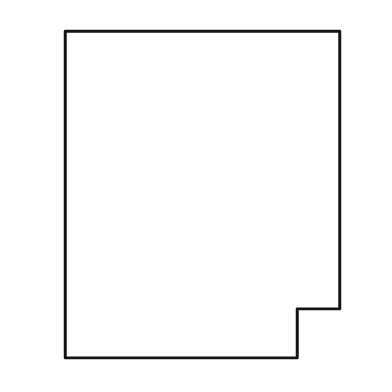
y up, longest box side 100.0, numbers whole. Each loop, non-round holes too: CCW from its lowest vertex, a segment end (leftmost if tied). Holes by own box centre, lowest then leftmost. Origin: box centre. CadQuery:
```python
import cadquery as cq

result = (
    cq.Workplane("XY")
    .moveTo(-42.0, -50.0)
    .lineTo(29.0, -50.0)
    .lineTo(29.0, -35.0)
    .lineTo(42.0, -35.0)
    .lineTo(42.0, 50.0)
    .lineTo(-42.0, 50.0)
    .close()
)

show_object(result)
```